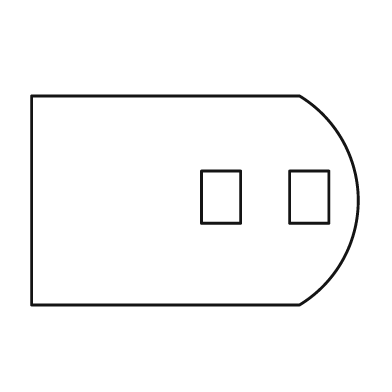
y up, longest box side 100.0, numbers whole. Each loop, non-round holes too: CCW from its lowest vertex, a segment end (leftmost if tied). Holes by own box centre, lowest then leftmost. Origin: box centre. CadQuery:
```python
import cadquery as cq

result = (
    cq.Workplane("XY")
    .moveTo(-50.0, -32.0)
    .lineTo(32.0, -32.0)
    .threePointArc((50.0, 0.0), (32.0, 32.0))
    .lineTo(-50.0, 32.0)
    .close()
    .moveTo(2.0, -7.0)
    .lineTo(14.0, -7.0)
    .lineTo(14.0, 9.0)
    .lineTo(2.0, 9.0)
    .close()
    .moveTo(29.0, -7.0)
    .lineTo(41.0, -7.0)
    .lineTo(41.0, 9.0)
    .lineTo(29.0, 9.0)
    .close()
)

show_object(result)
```